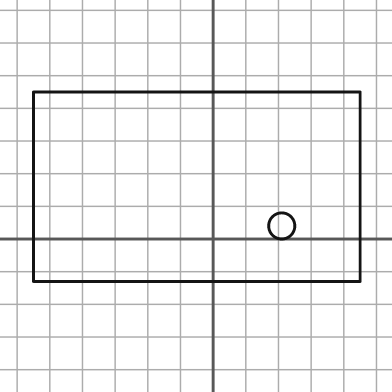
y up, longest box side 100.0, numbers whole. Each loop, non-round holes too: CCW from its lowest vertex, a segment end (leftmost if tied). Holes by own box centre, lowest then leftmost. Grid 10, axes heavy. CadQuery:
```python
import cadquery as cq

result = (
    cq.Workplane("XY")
    .moveTo(-55.0, -13.0)
    .lineTo(45.0, -13.0)
    .lineTo(45.0, 45.0)
    .lineTo(-55.0, 45.0)
    .close()
    .moveTo(21.0, 4.0)
    .circle(4.0)
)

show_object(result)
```